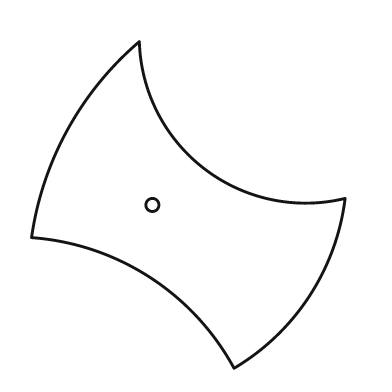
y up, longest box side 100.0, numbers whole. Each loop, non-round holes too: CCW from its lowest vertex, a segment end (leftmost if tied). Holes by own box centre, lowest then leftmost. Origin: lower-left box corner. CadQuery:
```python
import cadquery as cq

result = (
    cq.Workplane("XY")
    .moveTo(62.0, 0.0)
    .threePointArc((85.0, 22.0), (96.0, 52.0))
    .threePointArc((53.0, 61.0), (33.0, 100.0))
    .threePointArc((11.0, 73.0), (0.0, 40.0))
    .threePointArc((36.0, 28.0), (62.0, 0.0))
    .close()
    .moveTo(37.0, 50.0)
    .circle(2.0)
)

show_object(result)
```